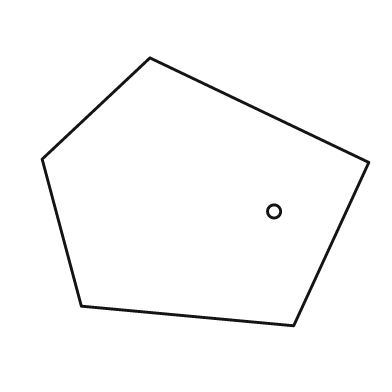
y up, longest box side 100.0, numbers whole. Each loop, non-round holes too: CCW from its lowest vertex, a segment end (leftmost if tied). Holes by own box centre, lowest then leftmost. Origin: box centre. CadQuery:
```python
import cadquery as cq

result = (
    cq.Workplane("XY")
    .moveTo(27.0, -41.0)
    .lineTo(50.0, 9.0)
    .lineTo(-17.0, 41.0)
    .lineTo(-50.0, 10.0)
    .lineTo(-38.0, -35.0)
    .close()
    .moveTo(21.0, -6.0)
    .circle(2.0)
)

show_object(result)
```